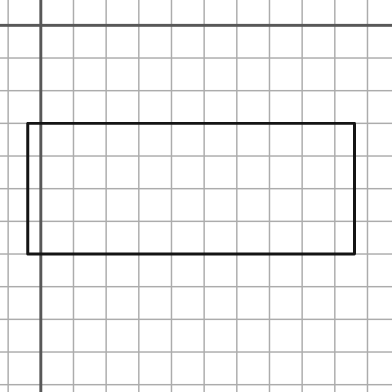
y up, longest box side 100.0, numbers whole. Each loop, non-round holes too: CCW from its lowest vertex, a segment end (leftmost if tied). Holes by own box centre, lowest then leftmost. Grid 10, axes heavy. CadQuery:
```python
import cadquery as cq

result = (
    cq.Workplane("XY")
    .moveTo(-4.0, -70.0)
    .lineTo(96.0, -70.0)
    .lineTo(96.0, -30.0)
    .lineTo(-4.0, -30.0)
    .close()
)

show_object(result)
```